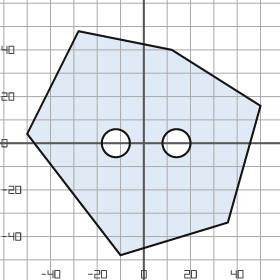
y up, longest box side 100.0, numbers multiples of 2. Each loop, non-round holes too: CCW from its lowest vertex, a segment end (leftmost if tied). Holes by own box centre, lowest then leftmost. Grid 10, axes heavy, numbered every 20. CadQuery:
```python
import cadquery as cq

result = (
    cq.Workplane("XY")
    .moveTo(-10.0, -48.0)
    .lineTo(36.0, -34.0)
    .lineTo(50.0, 16.0)
    .lineTo(12.0, 40.0)
    .lineTo(-28.0, 48.0)
    .lineTo(-50.0, 4.0)
    .close()
    .moveTo(-12.0, 0.0)
    .circle(6.0)
    .moveTo(14.0, 0.0)
    .circle(6.0)
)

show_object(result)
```